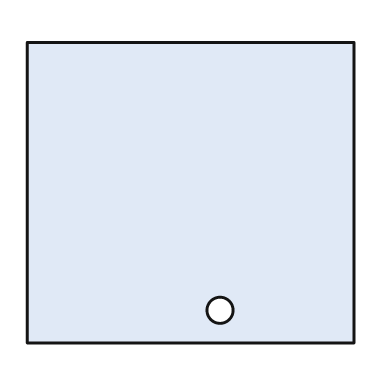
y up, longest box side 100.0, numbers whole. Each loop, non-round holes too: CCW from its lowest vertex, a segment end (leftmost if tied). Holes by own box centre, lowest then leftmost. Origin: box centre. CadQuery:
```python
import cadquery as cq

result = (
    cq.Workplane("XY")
    .moveTo(-50.0, -46.0)
    .lineTo(50.0, -46.0)
    .lineTo(50.0, 46.0)
    .lineTo(-50.0, 46.0)
    .close()
    .moveTo(9.0, -36.0)
    .circle(4.0)
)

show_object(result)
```